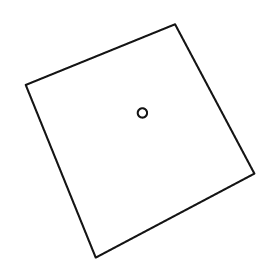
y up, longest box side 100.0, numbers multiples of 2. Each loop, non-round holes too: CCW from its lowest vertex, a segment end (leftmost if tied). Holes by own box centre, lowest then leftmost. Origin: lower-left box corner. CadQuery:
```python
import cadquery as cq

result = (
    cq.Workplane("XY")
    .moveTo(30.0, 0.0)
    .lineTo(98.0, 36.0)
    .lineTo(64.0, 100.0)
    .lineTo(0.0, 74.0)
    .close()
    .moveTo(50.0, 62.0)
    .circle(2.0)
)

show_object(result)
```